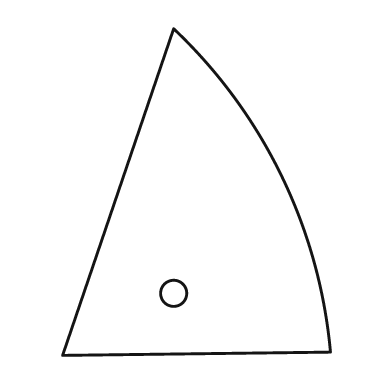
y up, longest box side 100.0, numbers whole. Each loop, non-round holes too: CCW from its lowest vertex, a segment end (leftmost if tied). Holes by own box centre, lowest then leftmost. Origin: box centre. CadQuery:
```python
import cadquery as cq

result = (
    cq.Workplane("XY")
    .moveTo(-41.0, -50.0)
    .lineTo(41.0, -49.0)
    .threePointArc((26.0, 5.0), (-7.0, 50.0))
    .close()
    .moveTo(-7.0, -31.0)
    .circle(4.0)
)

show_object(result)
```